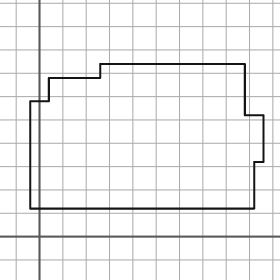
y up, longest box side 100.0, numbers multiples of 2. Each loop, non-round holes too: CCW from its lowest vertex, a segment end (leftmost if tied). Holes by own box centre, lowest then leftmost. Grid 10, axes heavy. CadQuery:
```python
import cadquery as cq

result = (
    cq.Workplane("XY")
    .moveTo(-4.0, 12.0)
    .lineTo(92.0, 12.0)
    .lineTo(92.0, 32.0)
    .lineTo(96.0, 32.0)
    .lineTo(96.0, 52.0)
    .lineTo(88.0, 52.0)
    .lineTo(88.0, 74.0)
    .lineTo(26.0, 74.0)
    .lineTo(26.0, 68.0)
    .lineTo(4.0, 68.0)
    .lineTo(4.0, 58.0)
    .lineTo(-4.0, 58.0)
    .close()
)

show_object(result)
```